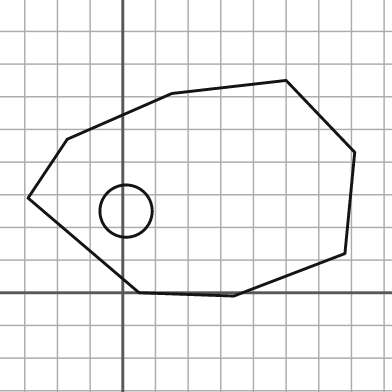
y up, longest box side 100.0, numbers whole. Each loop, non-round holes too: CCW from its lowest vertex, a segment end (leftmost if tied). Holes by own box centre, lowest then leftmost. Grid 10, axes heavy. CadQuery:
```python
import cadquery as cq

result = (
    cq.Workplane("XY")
    .moveTo(34.0, -1.0)
    .lineTo(68.0, 12.0)
    .lineTo(71.0, 43.0)
    .lineTo(50.0, 65.0)
    .lineTo(15.0, 61.0)
    .lineTo(-17.0, 47.0)
    .lineTo(-29.0, 29.0)
    .lineTo(5.0, 0.0)
    .close()
    .moveTo(1.0, 25.0)
    .circle(8.0)
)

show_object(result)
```